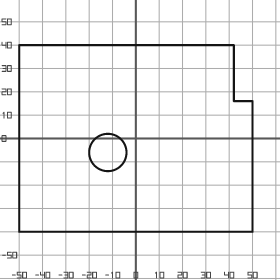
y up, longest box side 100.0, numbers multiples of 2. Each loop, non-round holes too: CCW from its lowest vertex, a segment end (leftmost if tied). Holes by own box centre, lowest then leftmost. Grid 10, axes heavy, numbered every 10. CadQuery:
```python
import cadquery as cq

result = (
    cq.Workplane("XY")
    .moveTo(-50.0, -40.0)
    .lineTo(50.0, -40.0)
    .lineTo(50.0, 16.0)
    .lineTo(42.0, 16.0)
    .lineTo(42.0, 40.0)
    .lineTo(-50.0, 40.0)
    .close()
    .moveTo(-12.0, -6.0)
    .circle(8.0)
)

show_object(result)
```